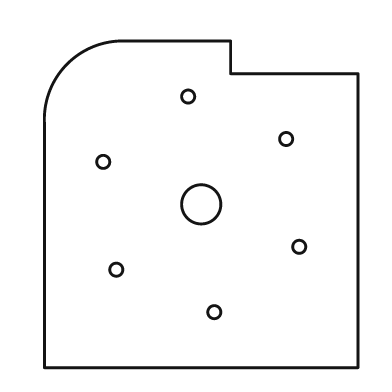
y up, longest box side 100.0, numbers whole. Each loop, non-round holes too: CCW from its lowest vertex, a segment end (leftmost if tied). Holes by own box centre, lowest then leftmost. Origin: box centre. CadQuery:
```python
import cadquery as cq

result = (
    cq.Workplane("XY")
    .moveTo(-48.0, -50.0)
    .lineTo(48.0, -50.0)
    .lineTo(48.0, 40.0)
    .lineTo(9.0, 40.0)
    .lineTo(9.0, 50.0)
    .lineTo(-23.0, 50.0)
    .threePointArc((-41.0, 43.0), (-48.0, 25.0))
    .close()
    .moveTo(4.0, -33.0)
    .circle(2.0)
    .moveTo(-26.0, -20.0)
    .circle(2.0)
    .moveTo(30.0, -13.0)
    .circle(2.0)
    .moveTo(0.0, 0.0)
    .circle(6.0)
    .moveTo(-30.0, 13.0)
    .circle(2.0)
    .moveTo(26.0, 20.0)
    .circle(2.0)
    .moveTo(-4.0, 33.0)
    .circle(2.0)
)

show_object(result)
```